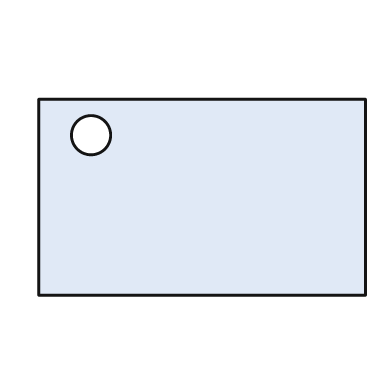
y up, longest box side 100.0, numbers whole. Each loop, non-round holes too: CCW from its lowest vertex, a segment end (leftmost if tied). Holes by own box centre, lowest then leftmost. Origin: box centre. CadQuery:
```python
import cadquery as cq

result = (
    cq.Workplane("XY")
    .moveTo(-50.0, -30.0)
    .lineTo(50.0, -30.0)
    .lineTo(50.0, 30.0)
    .lineTo(-50.0, 30.0)
    .close()
    .moveTo(-34.0, 19.0)
    .circle(6.0)
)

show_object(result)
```